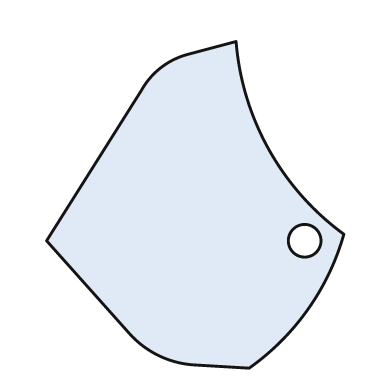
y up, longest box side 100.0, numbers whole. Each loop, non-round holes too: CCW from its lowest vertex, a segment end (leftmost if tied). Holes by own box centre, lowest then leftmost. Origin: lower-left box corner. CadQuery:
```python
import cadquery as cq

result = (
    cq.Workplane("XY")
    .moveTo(62.0, 0.0)
    .threePointArc((80.0, 18.0), (91.0, 41.0))
    .threePointArc((68.0, 67.0), (58.0, 100.0))
    .lineTo(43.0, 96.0)
    .threePointArc((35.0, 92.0), (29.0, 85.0))
    .lineTo(0.0, 39.0)
    .lineTo(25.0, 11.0)
    .threePointArc((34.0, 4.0), (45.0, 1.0))
    .close()
    .moveTo(79.0, 39.0)
    .circle(5.0)
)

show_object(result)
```